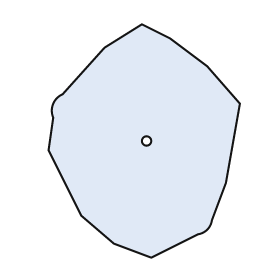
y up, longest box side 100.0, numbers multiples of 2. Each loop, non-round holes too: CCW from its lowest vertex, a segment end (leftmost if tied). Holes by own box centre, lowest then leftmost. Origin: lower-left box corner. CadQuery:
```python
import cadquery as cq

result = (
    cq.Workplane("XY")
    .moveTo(44.0, 0.0)
    .lineTo(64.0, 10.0)
    .threePointArc((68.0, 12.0), (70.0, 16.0))
    .lineTo(76.0, 32.0)
    .lineTo(82.0, 66.0)
    .lineTo(68.0, 82.0)
    .lineTo(52.0, 94.0)
    .lineTo(40.0, 100.0)
    .lineTo(24.0, 90.0)
    .lineTo(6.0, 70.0)
    .threePointArc((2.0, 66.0), (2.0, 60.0))
    .lineTo(0.0, 46.0)
    .lineTo(14.0, 18.0)
    .lineTo(28.0, 6.0)
    .close()
    .moveTo(42.0, 50.0)
    .circle(2.0)
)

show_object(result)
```